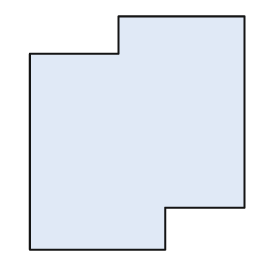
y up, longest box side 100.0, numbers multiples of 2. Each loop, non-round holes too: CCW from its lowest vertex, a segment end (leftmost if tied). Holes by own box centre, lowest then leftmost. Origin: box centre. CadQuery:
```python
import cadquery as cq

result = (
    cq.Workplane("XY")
    .moveTo(-46.0, -50.0)
    .lineTo(12.0, -50.0)
    .lineTo(12.0, -32.0)
    .lineTo(46.0, -32.0)
    .lineTo(46.0, 50.0)
    .lineTo(-8.0, 50.0)
    .lineTo(-8.0, 34.0)
    .lineTo(-46.0, 34.0)
    .close()
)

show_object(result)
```